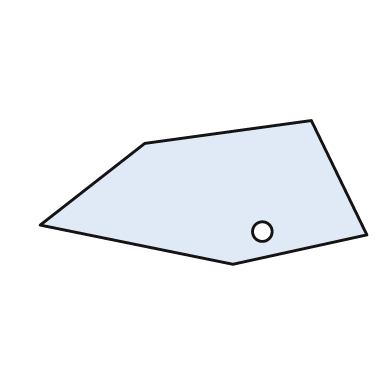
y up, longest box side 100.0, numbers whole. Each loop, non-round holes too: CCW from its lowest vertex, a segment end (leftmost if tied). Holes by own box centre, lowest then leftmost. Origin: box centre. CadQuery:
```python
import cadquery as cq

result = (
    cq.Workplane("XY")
    .moveTo(9.0, -22.0)
    .lineTo(50.0, -13.0)
    .lineTo(33.0, 22.0)
    .lineTo(-18.0, 15.0)
    .lineTo(-50.0, -10.0)
    .close()
    .moveTo(18.0, -12.0)
    .circle(3.0)
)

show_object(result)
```